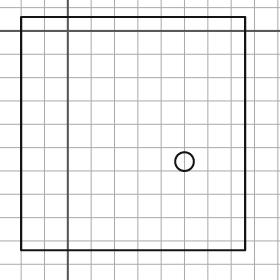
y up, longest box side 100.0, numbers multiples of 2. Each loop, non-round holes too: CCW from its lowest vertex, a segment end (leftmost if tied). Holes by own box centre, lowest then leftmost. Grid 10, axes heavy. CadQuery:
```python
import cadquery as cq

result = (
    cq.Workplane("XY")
    .moveTo(-20.0, -94.0)
    .lineTo(76.0, -94.0)
    .lineTo(76.0, 6.0)
    .lineTo(-20.0, 6.0)
    .close()
    .moveTo(50.0, -56.0)
    .circle(4.0)
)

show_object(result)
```